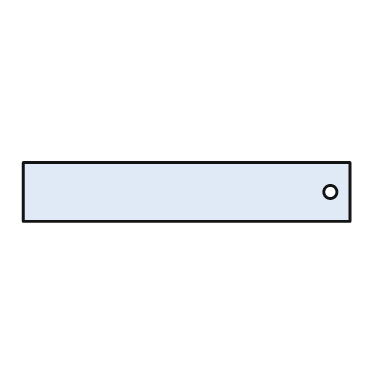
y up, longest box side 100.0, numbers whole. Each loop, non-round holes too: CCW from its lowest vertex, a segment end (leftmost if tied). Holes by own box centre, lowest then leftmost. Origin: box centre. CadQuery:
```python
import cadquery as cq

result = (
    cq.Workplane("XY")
    .moveTo(-50.0, -9.0)
    .lineTo(50.0, -9.0)
    .lineTo(50.0, 9.0)
    .lineTo(-50.0, 9.0)
    .close()
    .moveTo(44.0, 0.0)
    .circle(2.0)
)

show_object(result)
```